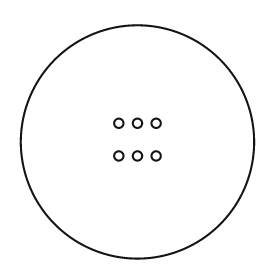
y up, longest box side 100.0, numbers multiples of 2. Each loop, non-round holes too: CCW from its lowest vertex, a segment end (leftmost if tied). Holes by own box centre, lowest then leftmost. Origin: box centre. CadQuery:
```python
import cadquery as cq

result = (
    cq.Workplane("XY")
    .moveTo(0.0, 0.0)
    .circle(50.0)
    .moveTo(-8.0, -6.0)
    .circle(2.0)
    .moveTo(0.0, -6.0)
    .circle(2.0)
    .moveTo(8.0, -6.0)
    .circle(2.0)
    .moveTo(-8.0, 8.0)
    .circle(2.0)
    .moveTo(0.0, 8.0)
    .circle(2.0)
    .moveTo(8.0, 8.0)
    .circle(2.0)
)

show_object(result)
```